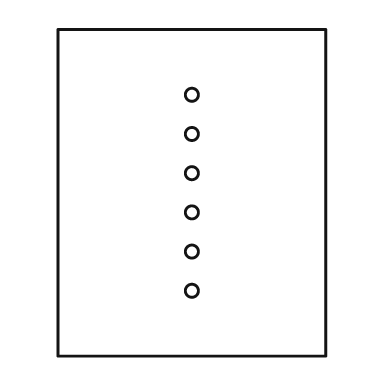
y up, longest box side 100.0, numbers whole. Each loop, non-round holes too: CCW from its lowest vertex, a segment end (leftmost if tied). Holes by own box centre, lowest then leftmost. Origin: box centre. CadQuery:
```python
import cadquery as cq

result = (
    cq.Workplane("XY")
    .moveTo(-41.0, -50.0)
    .lineTo(41.0, -50.0)
    .lineTo(41.0, 50.0)
    .lineTo(-41.0, 50.0)
    .close()
    .moveTo(0.0, -30.0)
    .circle(2.0)
    .moveTo(0.0, -18.0)
    .circle(2.0)
    .moveTo(0.0, -6.0)
    .circle(2.0)
    .moveTo(0.0, 6.0)
    .circle(2.0)
    .moveTo(0.0, 18.0)
    .circle(2.0)
    .moveTo(0.0, 30.0)
    .circle(2.0)
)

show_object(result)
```